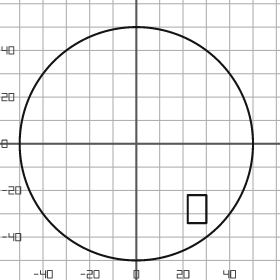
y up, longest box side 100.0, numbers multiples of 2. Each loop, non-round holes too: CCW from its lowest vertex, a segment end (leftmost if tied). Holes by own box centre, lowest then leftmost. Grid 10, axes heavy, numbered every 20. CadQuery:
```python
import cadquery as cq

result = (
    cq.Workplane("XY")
    .moveTo(0.0, 0.0)
    .circle(50.0)
    .moveTo(22.0, -34.0)
    .lineTo(30.0, -34.0)
    .lineTo(30.0, -22.0)
    .lineTo(22.0, -22.0)
    .close()
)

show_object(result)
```